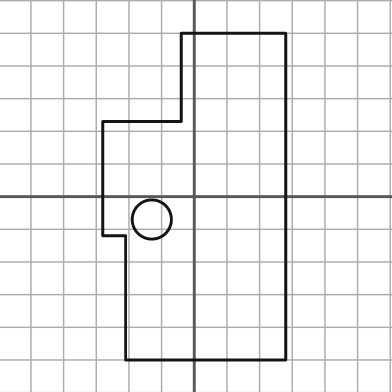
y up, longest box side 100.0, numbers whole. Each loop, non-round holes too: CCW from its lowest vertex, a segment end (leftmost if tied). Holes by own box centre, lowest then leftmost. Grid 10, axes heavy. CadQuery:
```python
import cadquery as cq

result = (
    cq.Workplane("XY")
    .moveTo(-21.0, -50.0)
    .lineTo(28.0, -50.0)
    .lineTo(28.0, 50.0)
    .lineTo(-4.0, 50.0)
    .lineTo(-4.0, 23.0)
    .lineTo(-28.0, 23.0)
    .lineTo(-28.0, -12.0)
    .lineTo(-21.0, -12.0)
    .close()
    .moveTo(-13.0, -7.0)
    .circle(6.0)
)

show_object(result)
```